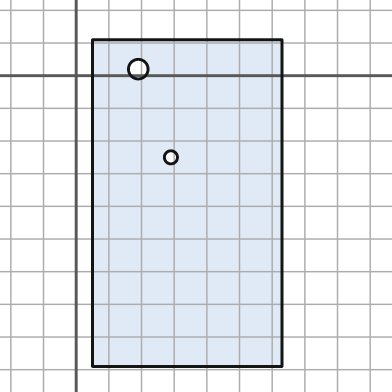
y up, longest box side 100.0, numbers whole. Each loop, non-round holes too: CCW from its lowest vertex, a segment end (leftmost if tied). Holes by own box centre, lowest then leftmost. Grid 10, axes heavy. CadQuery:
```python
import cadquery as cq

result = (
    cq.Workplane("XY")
    .moveTo(5.0, -89.0)
    .lineTo(63.0, -89.0)
    .lineTo(63.0, 11.0)
    .lineTo(5.0, 11.0)
    .close()
    .moveTo(29.0, -25.0)
    .circle(2.0)
    .moveTo(19.0, 2.0)
    .circle(3.0)
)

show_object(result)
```